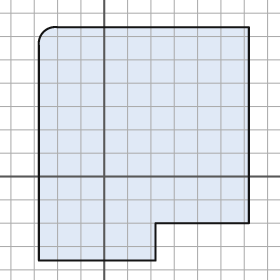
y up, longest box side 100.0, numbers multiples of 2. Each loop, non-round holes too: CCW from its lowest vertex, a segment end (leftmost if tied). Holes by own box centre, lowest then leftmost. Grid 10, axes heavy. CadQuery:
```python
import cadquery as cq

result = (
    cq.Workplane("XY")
    .moveTo(-28.0, -36.0)
    .lineTo(22.0, -36.0)
    .lineTo(22.0, -20.0)
    .lineTo(62.0, -20.0)
    .lineTo(62.0, 64.0)
    .lineTo(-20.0, 64.0)
    .threePointArc((-26.0, 62.0), (-28.0, 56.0))
    .close()
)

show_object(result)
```